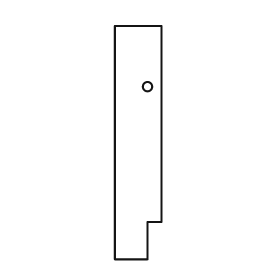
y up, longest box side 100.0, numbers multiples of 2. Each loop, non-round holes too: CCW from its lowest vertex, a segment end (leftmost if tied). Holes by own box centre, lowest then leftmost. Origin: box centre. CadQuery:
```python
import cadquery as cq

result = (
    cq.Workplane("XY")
    .moveTo(-10.0, -50.0)
    .lineTo(4.0, -50.0)
    .lineTo(4.0, -34.0)
    .lineTo(10.0, -34.0)
    .lineTo(10.0, 50.0)
    .lineTo(-10.0, 50.0)
    .close()
    .moveTo(4.0, 24.0)
    .circle(2.0)
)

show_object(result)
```